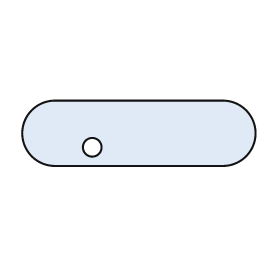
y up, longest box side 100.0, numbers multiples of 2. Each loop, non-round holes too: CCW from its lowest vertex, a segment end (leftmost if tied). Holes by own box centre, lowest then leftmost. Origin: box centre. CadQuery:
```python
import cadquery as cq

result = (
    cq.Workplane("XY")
    .moveTo(-36.0, -14.0)
    .lineTo(36.0, -14.0)
    .threePointArc((50.0, 0.0), (36.0, 14.0))
    .lineTo(-36.0, 14.0)
    .threePointArc((-50.0, 0.0), (-36.0, -14.0))
    .close()
    .moveTo(-20.0, -6.0)
    .circle(4.0)
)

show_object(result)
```